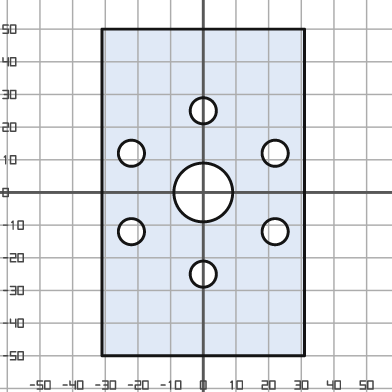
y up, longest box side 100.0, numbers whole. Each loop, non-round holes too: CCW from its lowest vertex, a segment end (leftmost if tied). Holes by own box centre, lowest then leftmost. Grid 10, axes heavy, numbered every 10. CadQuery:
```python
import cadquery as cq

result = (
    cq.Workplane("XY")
    .moveTo(-31.0, -50.0)
    .lineTo(31.0, -50.0)
    .lineTo(31.0, 50.0)
    .lineTo(-31.0, 50.0)
    .close()
    .moveTo(0.0, -25.0)
    .circle(4.0)
    .moveTo(-22.0, -12.0)
    .circle(4.0)
    .moveTo(22.0, -12.0)
    .circle(4.0)
    .moveTo(0.0, 0.0)
    .circle(9.0)
    .moveTo(-22.0, 12.0)
    .circle(4.0)
    .moveTo(22.0, 12.0)
    .circle(4.0)
    .moveTo(0.0, 25.0)
    .circle(4.0)
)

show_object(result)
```